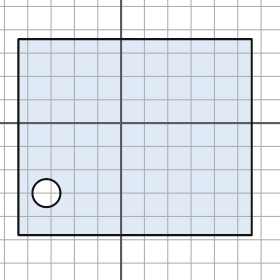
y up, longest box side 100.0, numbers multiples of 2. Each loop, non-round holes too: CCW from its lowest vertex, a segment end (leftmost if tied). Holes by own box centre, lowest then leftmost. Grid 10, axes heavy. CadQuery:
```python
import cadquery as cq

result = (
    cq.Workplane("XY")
    .moveTo(-44.0, -48.0)
    .lineTo(56.0, -48.0)
    .lineTo(56.0, 36.0)
    .lineTo(-44.0, 36.0)
    .close()
    .moveTo(-32.0, -30.0)
    .circle(6.0)
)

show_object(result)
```